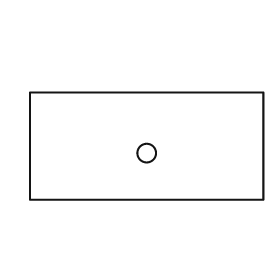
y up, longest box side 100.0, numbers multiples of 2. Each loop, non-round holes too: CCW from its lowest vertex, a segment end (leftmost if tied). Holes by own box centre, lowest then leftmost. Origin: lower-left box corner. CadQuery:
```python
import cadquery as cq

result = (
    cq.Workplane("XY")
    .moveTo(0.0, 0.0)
    .lineTo(100.0, 0.0)
    .lineTo(100.0, 46.0)
    .lineTo(0.0, 46.0)
    .close()
    .moveTo(50.0, 20.0)
    .circle(4.0)
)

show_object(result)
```